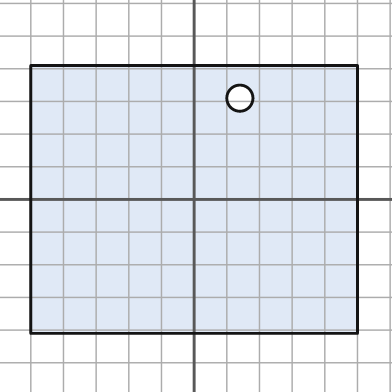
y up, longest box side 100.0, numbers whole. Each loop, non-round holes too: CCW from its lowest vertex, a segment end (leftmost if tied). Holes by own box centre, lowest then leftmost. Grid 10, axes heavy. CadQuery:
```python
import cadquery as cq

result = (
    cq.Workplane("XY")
    .moveTo(-50.0, -41.0)
    .lineTo(50.0, -41.0)
    .lineTo(50.0, 41.0)
    .lineTo(-50.0, 41.0)
    .close()
    .moveTo(14.0, 31.0)
    .circle(4.0)
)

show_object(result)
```